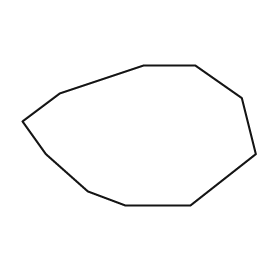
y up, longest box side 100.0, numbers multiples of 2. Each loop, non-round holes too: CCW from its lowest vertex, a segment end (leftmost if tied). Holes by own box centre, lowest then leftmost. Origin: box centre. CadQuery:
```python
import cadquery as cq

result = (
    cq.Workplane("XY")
    .moveTo(-6.0, -30.0)
    .lineTo(22.0, -30.0)
    .lineTo(50.0, -8.0)
    .lineTo(44.0, 16.0)
    .lineTo(24.0, 30.0)
    .lineTo(2.0, 30.0)
    .lineTo(-34.0, 18.0)
    .lineTo(-50.0, 6.0)
    .lineTo(-40.0, -8.0)
    .lineTo(-22.0, -24.0)
    .close()
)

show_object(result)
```